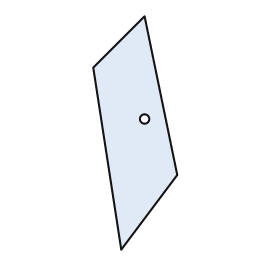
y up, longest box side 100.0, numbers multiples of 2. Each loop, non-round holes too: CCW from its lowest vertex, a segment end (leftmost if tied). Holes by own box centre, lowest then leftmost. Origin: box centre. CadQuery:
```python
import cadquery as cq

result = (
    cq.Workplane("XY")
    .moveTo(-6.0, -50.0)
    .lineTo(18.0, -18.0)
    .lineTo(4.0, 50.0)
    .lineTo(-18.0, 28.0)
    .close()
    .moveTo(4.0, 6.0)
    .circle(2.0)
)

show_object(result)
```